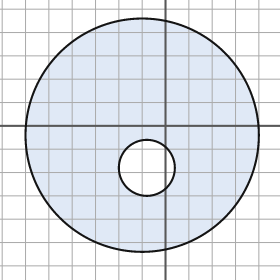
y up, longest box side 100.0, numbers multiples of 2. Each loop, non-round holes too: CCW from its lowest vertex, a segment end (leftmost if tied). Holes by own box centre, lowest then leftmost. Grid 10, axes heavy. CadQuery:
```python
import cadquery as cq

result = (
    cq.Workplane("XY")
    .moveTo(-10.0, -4.0)
    .circle(50.0)
    .moveTo(-8.0, -18.0)
    .circle(12.0)
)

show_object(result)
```